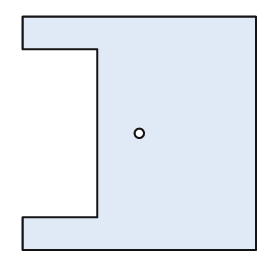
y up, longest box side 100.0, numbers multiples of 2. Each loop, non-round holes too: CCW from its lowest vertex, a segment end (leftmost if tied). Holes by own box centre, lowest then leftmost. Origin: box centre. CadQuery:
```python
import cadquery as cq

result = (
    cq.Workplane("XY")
    .moveTo(-50.0, -50.0)
    .lineTo(50.0, -50.0)
    .lineTo(50.0, 50.0)
    .lineTo(-50.0, 50.0)
    .lineTo(-50.0, 36.0)
    .lineTo(-18.0, 36.0)
    .lineTo(-18.0, -36.0)
    .lineTo(-50.0, -36.0)
    .close()
    .moveTo(0.0, 0.0)
    .circle(2.0)
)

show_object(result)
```